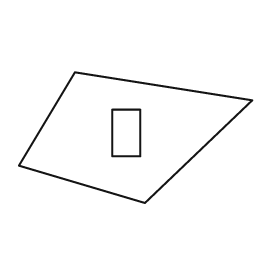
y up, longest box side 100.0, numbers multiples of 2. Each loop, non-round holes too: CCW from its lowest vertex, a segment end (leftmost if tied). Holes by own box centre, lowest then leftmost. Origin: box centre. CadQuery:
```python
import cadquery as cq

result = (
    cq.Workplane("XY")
    .moveTo(4.0, -28.0)
    .lineTo(50.0, 16.0)
    .lineTo(-26.0, 28.0)
    .lineTo(-50.0, -12.0)
    .close()
    .moveTo(-10.0, -8.0)
    .lineTo(2.0, -8.0)
    .lineTo(2.0, 12.0)
    .lineTo(-10.0, 12.0)
    .close()
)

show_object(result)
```